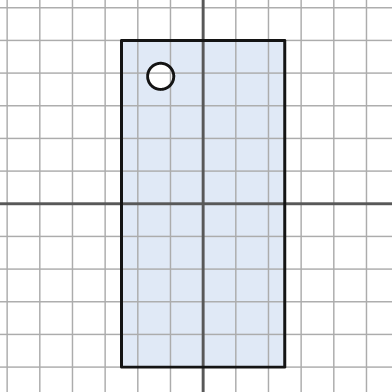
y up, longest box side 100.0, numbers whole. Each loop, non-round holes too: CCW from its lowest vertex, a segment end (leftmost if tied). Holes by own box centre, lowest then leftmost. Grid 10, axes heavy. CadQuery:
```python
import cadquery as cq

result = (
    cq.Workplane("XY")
    .moveTo(-25.0, -50.0)
    .lineTo(25.0, -50.0)
    .lineTo(25.0, 50.0)
    .lineTo(-25.0, 50.0)
    .close()
    .moveTo(-13.0, 39.0)
    .circle(4.0)
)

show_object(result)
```